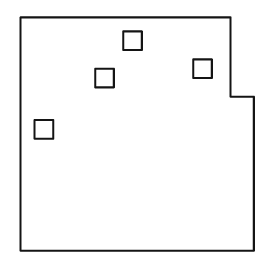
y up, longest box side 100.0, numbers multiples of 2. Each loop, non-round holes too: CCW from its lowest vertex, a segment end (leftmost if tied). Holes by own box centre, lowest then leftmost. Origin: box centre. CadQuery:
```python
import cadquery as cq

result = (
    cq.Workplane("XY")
    .moveTo(-50.0, -50.0)
    .lineTo(50.0, -50.0)
    .lineTo(50.0, 16.0)
    .lineTo(40.0, 16.0)
    .lineTo(40.0, 50.0)
    .lineTo(-50.0, 50.0)
    .close()
    .moveTo(-44.0, -2.0)
    .lineTo(-36.0, -2.0)
    .lineTo(-36.0, 6.0)
    .lineTo(-44.0, 6.0)
    .close()
    .moveTo(-18.0, 20.0)
    .lineTo(-10.0, 20.0)
    .lineTo(-10.0, 28.0)
    .lineTo(-18.0, 28.0)
    .close()
    .moveTo(24.0, 24.0)
    .lineTo(32.0, 24.0)
    .lineTo(32.0, 32.0)
    .lineTo(24.0, 32.0)
    .close()
    .moveTo(-6.0, 36.0)
    .lineTo(2.0, 36.0)
    .lineTo(2.0, 44.0)
    .lineTo(-6.0, 44.0)
    .close()
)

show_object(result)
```